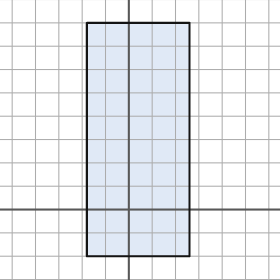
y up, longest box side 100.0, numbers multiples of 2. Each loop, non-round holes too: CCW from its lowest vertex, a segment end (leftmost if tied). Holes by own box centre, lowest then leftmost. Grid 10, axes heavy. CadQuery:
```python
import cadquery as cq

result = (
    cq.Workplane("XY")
    .moveTo(-18.0, -20.0)
    .lineTo(26.0, -20.0)
    .lineTo(26.0, 80.0)
    .lineTo(-18.0, 80.0)
    .close()
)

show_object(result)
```